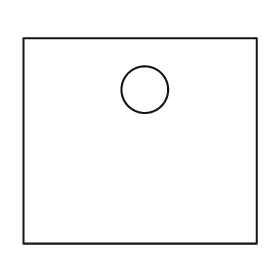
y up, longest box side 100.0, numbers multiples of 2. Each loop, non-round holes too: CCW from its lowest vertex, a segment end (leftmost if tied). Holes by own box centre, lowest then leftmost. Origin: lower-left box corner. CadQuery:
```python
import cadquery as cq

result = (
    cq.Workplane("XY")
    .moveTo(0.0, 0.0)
    .lineTo(100.0, 0.0)
    .lineTo(100.0, 88.0)
    .lineTo(0.0, 88.0)
    .close()
    .moveTo(52.0, 66.0)
    .circle(10.0)
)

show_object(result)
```